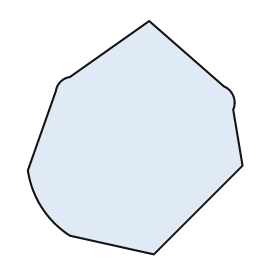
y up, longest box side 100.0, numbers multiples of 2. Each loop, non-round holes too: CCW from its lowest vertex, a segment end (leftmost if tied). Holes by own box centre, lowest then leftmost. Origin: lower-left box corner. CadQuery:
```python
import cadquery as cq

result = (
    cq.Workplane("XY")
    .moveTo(54.0, 0.0)
    .lineTo(92.0, 38.0)
    .lineTo(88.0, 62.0)
    .threePointArc((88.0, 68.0), (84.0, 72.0))
    .lineTo(52.0, 100.0)
    .lineTo(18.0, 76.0)
    .threePointArc((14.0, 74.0), (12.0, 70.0))
    .lineTo(0.0, 36.0)
    .threePointArc((6.0, 20.0), (18.0, 8.0))
    .close()
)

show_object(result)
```